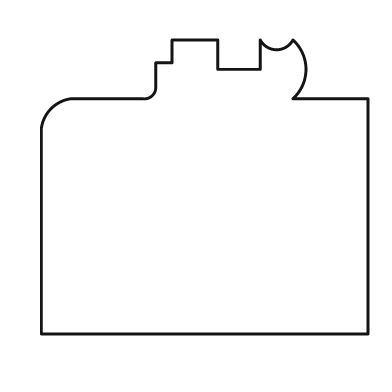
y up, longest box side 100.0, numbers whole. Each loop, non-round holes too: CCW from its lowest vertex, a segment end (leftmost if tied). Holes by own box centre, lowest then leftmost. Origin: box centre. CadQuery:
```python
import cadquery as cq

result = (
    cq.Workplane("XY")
    .moveTo(-50.0, -45.0)
    .lineTo(50.0, -45.0)
    .lineTo(50.0, 27.0)
    .lineTo(27.0, 27.0)
    .threePointArc((31.0, 36.0), (27.0, 45.0))
    .threePointArc((22.0, 42.0), (17.0, 45.0))
    .lineTo(17.0, 36.0)
    .lineTo(4.0, 36.0)
    .lineTo(4.0, 45.0)
    .lineTo(-10.0, 45.0)
    .lineTo(-10.0, 38.0)
    .lineTo(-15.0, 38.0)
    .lineTo(-15.0, 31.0)
    .threePointArc((-16.0, 28.0), (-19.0, 27.0))
    .lineTo(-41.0, 27.0)
    .threePointArc((-47.0, 24.0), (-50.0, 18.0))
    .close()
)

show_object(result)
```